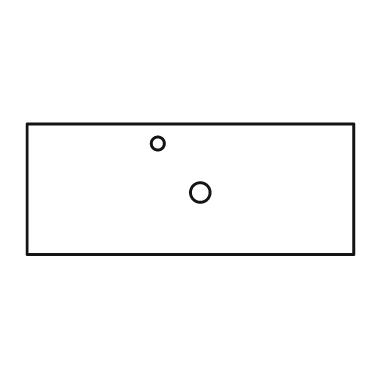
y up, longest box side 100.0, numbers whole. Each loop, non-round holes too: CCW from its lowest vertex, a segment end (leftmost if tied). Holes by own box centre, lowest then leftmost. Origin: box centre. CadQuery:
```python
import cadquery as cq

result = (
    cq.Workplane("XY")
    .moveTo(-50.0, -20.0)
    .lineTo(50.0, -20.0)
    .lineTo(50.0, 20.0)
    .lineTo(-50.0, 20.0)
    .close()
    .moveTo(3.0, -1.0)
    .circle(3.0)
    .moveTo(-10.0, 14.0)
    .circle(2.0)
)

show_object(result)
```